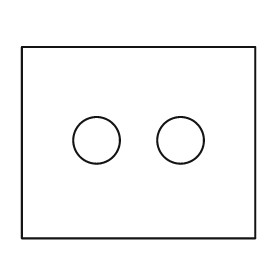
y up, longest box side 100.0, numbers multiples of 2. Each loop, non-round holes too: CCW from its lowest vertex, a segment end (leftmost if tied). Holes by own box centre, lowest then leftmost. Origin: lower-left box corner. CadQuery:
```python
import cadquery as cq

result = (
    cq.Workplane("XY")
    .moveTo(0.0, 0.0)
    .lineTo(100.0, 0.0)
    .lineTo(100.0, 82.0)
    .lineTo(0.0, 82.0)
    .close()
    .moveTo(32.0, 42.0)
    .circle(10.0)
    .moveTo(68.0, 42.0)
    .circle(10.0)
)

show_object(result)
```